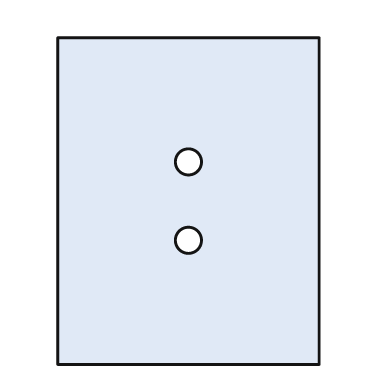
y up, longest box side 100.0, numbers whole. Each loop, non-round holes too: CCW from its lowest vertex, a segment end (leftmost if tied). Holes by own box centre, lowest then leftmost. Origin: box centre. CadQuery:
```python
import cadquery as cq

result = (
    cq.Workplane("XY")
    .moveTo(-40.0, -50.0)
    .lineTo(40.0, -50.0)
    .lineTo(40.0, 50.0)
    .lineTo(-40.0, 50.0)
    .close()
    .moveTo(0.0, -12.0)
    .circle(4.0)
    .moveTo(0.0, 12.0)
    .circle(4.0)
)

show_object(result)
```